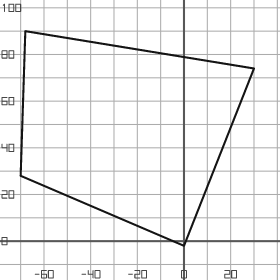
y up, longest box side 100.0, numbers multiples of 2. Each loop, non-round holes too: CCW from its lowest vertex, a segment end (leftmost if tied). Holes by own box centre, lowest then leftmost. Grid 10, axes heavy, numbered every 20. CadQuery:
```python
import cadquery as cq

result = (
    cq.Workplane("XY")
    .moveTo(0.0, -2.0)
    .lineTo(30.0, 74.0)
    .lineTo(-68.0, 90.0)
    .lineTo(-70.0, 28.0)
    .close()
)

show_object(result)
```